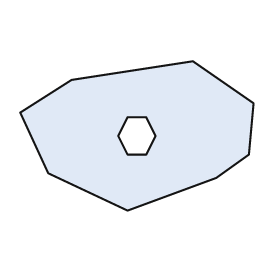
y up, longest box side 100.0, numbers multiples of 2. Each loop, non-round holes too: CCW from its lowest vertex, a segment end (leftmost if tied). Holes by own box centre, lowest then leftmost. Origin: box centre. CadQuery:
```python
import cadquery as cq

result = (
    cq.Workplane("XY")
    .moveTo(-4.0, -32.0)
    .lineTo(34.0, -18.0)
    .lineTo(48.0, -8.0)
    .lineTo(50.0, 14.0)
    .lineTo(24.0, 32.0)
    .lineTo(-28.0, 24.0)
    .lineTo(-50.0, 10.0)
    .lineTo(-38.0, -16.0)
    .close()
    .moveTo(-4.0, -8.0)
    .lineTo(4.0, -8.0)
    .lineTo(8.0, 0.0)
    .lineTo(4.0, 8.0)
    .lineTo(-4.0, 8.0)
    .lineTo(-8.0, 0.0)
    .close()
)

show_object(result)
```